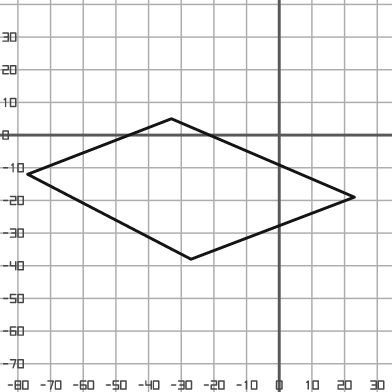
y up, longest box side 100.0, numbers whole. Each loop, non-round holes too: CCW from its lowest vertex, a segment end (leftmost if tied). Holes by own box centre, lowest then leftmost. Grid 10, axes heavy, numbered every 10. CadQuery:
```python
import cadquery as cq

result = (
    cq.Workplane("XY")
    .moveTo(-27.0, -38.0)
    .lineTo(23.0, -19.0)
    .lineTo(-33.0, 5.0)
    .lineTo(-77.0, -12.0)
    .close()
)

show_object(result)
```